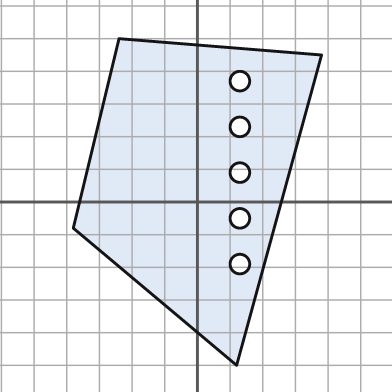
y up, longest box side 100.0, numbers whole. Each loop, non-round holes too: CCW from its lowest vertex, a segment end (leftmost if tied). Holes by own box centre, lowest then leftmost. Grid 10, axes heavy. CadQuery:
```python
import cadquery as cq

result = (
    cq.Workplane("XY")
    .moveTo(12.0, -50.0)
    .lineTo(38.0, 45.0)
    .lineTo(-24.0, 50.0)
    .lineTo(-38.0, -8.0)
    .close()
    .moveTo(13.0, -19.0)
    .circle(3.0)
    .moveTo(13.0, -5.0)
    .circle(3.0)
    .moveTo(13.0, 9.0)
    .circle(3.0)
    .moveTo(13.0, 23.0)
    .circle(3.0)
    .moveTo(13.0, 37.0)
    .circle(3.0)
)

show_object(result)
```